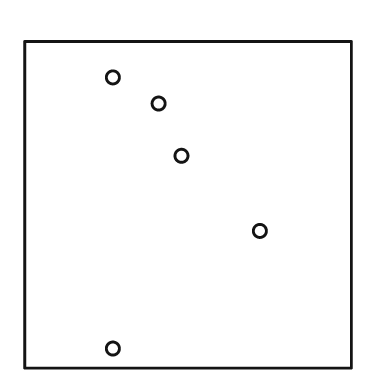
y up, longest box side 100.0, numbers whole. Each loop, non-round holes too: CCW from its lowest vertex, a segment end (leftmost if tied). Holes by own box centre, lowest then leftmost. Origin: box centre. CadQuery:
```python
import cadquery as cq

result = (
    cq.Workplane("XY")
    .moveTo(-50.0, -50.0)
    .lineTo(50.0, -50.0)
    .lineTo(50.0, 50.0)
    .lineTo(-50.0, 50.0)
    .close()
    .moveTo(-23.0, -44.0)
    .circle(2.0)
    .moveTo(22.0, -8.0)
    .circle(2.0)
    .moveTo(-2.0, 15.0)
    .circle(2.0)
    .moveTo(-9.0, 31.0)
    .circle(2.0)
    .moveTo(-23.0, 39.0)
    .circle(2.0)
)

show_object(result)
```